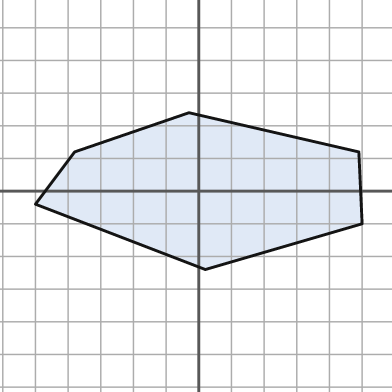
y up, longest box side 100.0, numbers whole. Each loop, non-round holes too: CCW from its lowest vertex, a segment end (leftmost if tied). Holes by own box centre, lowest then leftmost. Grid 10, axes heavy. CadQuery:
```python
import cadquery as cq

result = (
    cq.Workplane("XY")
    .moveTo(2.0, -24.0)
    .lineTo(50.0, -10.0)
    .lineTo(49.0, 12.0)
    .lineTo(-3.0, 24.0)
    .lineTo(-38.0, 12.0)
    .lineTo(-50.0, -4.0)
    .close()
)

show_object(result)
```